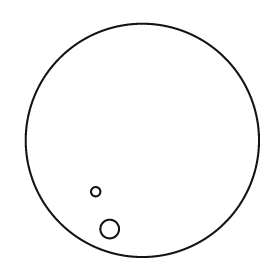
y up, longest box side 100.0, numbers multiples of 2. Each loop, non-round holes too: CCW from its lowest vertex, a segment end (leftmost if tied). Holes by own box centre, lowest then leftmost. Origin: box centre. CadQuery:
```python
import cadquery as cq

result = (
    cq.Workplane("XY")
    .moveTo(0.0, 0.0)
    .circle(50.0)
    .moveTo(-14.0, -38.0)
    .circle(4.0)
    .moveTo(-20.0, -22.0)
    .circle(2.0)
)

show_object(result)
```